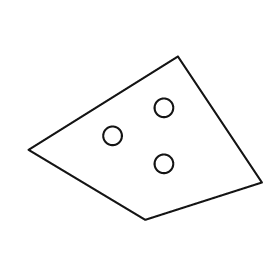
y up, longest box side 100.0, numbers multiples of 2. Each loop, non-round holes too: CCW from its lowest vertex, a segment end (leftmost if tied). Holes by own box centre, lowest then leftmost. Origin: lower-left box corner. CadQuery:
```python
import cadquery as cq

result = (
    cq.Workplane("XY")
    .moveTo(50.0, 0.0)
    .lineTo(100.0, 16.0)
    .lineTo(64.0, 70.0)
    .lineTo(0.0, 30.0)
    .close()
    .moveTo(58.0, 24.0)
    .circle(4.0)
    .moveTo(36.0, 36.0)
    .circle(4.0)
    .moveTo(58.0, 48.0)
    .circle(4.0)
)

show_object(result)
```